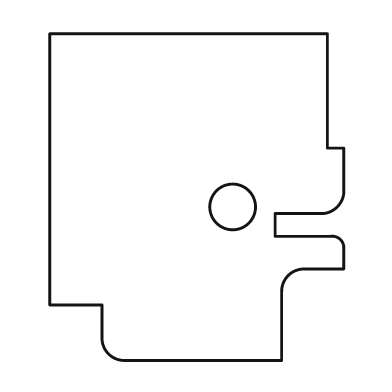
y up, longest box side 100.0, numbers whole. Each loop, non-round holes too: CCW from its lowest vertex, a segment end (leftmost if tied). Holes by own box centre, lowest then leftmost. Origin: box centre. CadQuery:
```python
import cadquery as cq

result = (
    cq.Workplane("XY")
    .moveTo(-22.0, -50.0)
    .lineTo(26.0, -50.0)
    .lineTo(26.0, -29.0)
    .threePointArc((28.0, -24.0), (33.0, -22.0))
    .lineTo(45.0, -22.0)
    .lineTo(45.0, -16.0)
    .threePointArc((44.0, -13.0), (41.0, -12.0))
    .lineTo(24.0, -12.0)
    .lineTo(24.0, -5.0)
    .lineTo(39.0, -5.0)
    .threePointArc((43.0, -3.0), (45.0, 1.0))
    .lineTo(45.0, 15.0)
    .lineTo(40.0, 15.0)
    .lineTo(40.0, 50.0)
    .lineTo(-45.0, 50.0)
    .lineTo(-45.0, -33.0)
    .lineTo(-29.0, -33.0)
    .lineTo(-29.0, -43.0)
    .threePointArc((-27.0, -48.0), (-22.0, -50.0))
    .close()
    .moveTo(11.0, -3.0)
    .circle(7.0)
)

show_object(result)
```